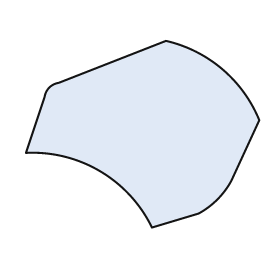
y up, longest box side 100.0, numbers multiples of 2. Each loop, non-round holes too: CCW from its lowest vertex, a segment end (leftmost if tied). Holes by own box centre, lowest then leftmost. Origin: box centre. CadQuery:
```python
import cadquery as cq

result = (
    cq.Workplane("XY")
    .moveTo(4.0, -40.0)
    .lineTo(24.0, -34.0)
    .threePointArc((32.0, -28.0), (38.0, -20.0))
    .lineTo(50.0, 6.0)
    .threePointArc((34.0, 28.0), (10.0, 40.0))
    .lineTo(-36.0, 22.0)
    .threePointArc((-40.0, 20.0), (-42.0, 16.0))
    .lineTo(-50.0, -8.0)
    .threePointArc((-18.0, -16.0), (4.0, -40.0))
    .close()
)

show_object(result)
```